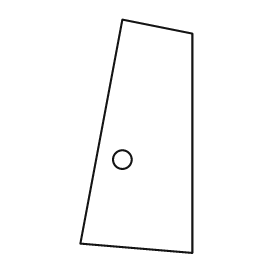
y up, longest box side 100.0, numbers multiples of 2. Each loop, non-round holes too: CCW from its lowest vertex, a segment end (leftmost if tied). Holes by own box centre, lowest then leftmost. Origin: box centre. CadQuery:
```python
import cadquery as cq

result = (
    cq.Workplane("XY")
    .moveTo(24.0, -50.0)
    .lineTo(24.0, 44.0)
    .lineTo(-6.0, 50.0)
    .lineTo(-24.0, -46.0)
    .close()
    .moveTo(-6.0, -10.0)
    .circle(4.0)
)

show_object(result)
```